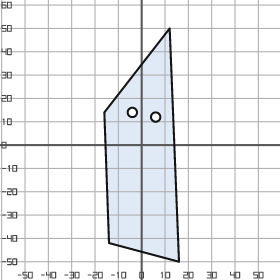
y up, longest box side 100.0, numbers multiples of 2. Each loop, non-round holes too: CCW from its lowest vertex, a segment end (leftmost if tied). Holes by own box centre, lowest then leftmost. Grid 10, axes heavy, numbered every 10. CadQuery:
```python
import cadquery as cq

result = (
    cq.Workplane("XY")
    .moveTo(16.0, -50.0)
    .lineTo(12.0, 50.0)
    .lineTo(-16.0, 14.0)
    .lineTo(-14.0, -42.0)
    .close()
    .moveTo(6.0, 12.0)
    .circle(2.0)
    .moveTo(-4.0, 14.0)
    .circle(2.0)
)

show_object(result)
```